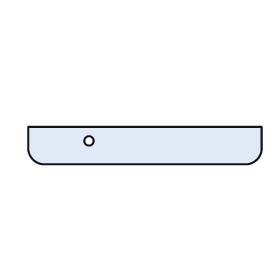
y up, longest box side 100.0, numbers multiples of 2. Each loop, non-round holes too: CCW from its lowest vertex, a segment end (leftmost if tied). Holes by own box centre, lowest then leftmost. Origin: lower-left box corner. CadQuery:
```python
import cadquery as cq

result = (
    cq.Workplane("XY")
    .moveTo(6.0, 0.0)
    .lineTo(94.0, 0.0)
    .threePointArc((98.0, 2.0), (100.0, 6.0))
    .lineTo(100.0, 16.0)
    .lineTo(0.0, 16.0)
    .lineTo(0.0, 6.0)
    .threePointArc((2.0, 2.0), (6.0, 0.0))
    .close()
    .moveTo(26.0, 10.0)
    .circle(2.0)
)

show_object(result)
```